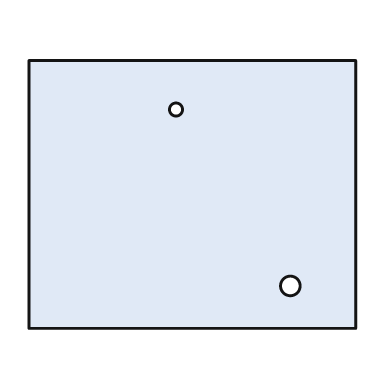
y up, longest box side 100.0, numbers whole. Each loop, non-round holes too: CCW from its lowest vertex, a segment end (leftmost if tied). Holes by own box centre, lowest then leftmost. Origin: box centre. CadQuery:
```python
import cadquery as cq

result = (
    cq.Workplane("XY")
    .moveTo(-50.0, -41.0)
    .lineTo(50.0, -41.0)
    .lineTo(50.0, 41.0)
    .lineTo(-50.0, 41.0)
    .close()
    .moveTo(30.0, -28.0)
    .circle(3.0)
    .moveTo(-5.0, 26.0)
    .circle(2.0)
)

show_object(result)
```